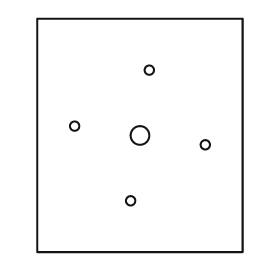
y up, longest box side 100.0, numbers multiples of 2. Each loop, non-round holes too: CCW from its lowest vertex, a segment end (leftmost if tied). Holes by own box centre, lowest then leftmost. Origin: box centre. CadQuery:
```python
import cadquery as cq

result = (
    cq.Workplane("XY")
    .moveTo(-44.0, -50.0)
    .lineTo(44.0, -50.0)
    .lineTo(44.0, 50.0)
    .lineTo(-44.0, 50.0)
    .close()
    .moveTo(-4.0, -28.0)
    .circle(2.0)
    .moveTo(28.0, -4.0)
    .circle(2.0)
    .moveTo(0.0, 0.0)
    .circle(4.0)
    .moveTo(-28.0, 4.0)
    .circle(2.0)
    .moveTo(4.0, 28.0)
    .circle(2.0)
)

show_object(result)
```